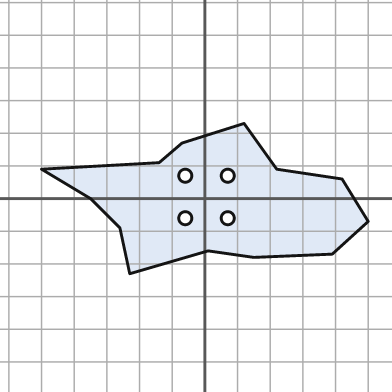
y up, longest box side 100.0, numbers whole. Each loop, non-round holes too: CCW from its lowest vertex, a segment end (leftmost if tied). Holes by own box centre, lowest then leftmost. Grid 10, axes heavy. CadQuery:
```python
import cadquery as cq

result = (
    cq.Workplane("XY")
    .moveTo(-23.0, -23.0)
    .lineTo(1.0, -16.0)
    .lineTo(15.0, -18.0)
    .lineTo(39.0, -17.0)
    .lineTo(50.0, -7.0)
    .lineTo(42.0, 6.0)
    .lineTo(22.0, 9.0)
    .lineTo(12.0, 23.0)
    .lineTo(-7.0, 17.0)
    .lineTo(-14.0, 11.0)
    .lineTo(-50.0, 9.0)
    .lineTo(-35.0, 0.0)
    .lineTo(-26.0, -9.0)
    .close()
    .moveTo(-6.0, -6.0)
    .circle(2.0)
    .moveTo(7.0, -6.0)
    .circle(2.0)
    .moveTo(-6.0, 7.0)
    .circle(2.0)
    .moveTo(7.0, 7.0)
    .circle(2.0)
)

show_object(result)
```